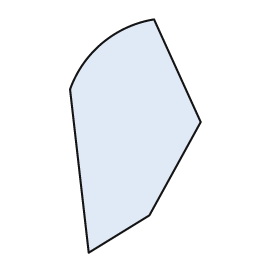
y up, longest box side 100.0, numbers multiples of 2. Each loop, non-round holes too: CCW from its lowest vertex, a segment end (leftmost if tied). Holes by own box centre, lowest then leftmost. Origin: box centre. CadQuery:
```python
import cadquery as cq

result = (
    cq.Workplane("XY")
    .moveTo(-20.0, -50.0)
    .lineTo(6.0, -34.0)
    .lineTo(28.0, 6.0)
    .lineTo(8.0, 50.0)
    .threePointArc((-14.0, 40.0), (-28.0, 20.0))
    .close()
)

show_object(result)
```